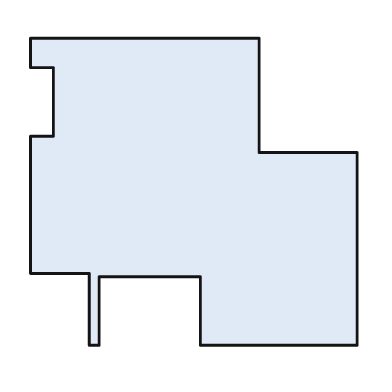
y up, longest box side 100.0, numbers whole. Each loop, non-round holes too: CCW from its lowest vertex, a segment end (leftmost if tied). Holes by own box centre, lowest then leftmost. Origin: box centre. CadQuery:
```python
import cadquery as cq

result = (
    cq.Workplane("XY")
    .moveTo(-32.0, -47.0)
    .lineTo(-29.0, -47.0)
    .lineTo(-29.0, -26.0)
    .lineTo(2.0, -26.0)
    .lineTo(2.0, -47.0)
    .lineTo(50.0, -47.0)
    .lineTo(50.0, 12.0)
    .lineTo(20.0, 12.0)
    .lineTo(20.0, 47.0)
    .lineTo(-50.0, 47.0)
    .lineTo(-50.0, 38.0)
    .lineTo(-43.0, 38.0)
    .lineTo(-43.0, 17.0)
    .lineTo(-50.0, 17.0)
    .lineTo(-50.0, -25.0)
    .lineTo(-32.0, -25.0)
    .close()
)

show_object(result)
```